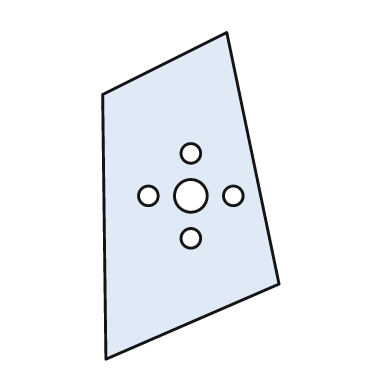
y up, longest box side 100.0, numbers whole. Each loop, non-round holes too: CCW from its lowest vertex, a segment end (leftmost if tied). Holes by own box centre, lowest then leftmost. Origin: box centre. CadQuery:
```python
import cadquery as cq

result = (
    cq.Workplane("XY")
    .moveTo(-26.0, -50.0)
    .lineTo(27.0, -27.0)
    .lineTo(11.0, 50.0)
    .lineTo(-27.0, 31.0)
    .close()
    .moveTo(0.0, -13.0)
    .circle(3.0)
    .moveTo(-13.0, 0.0)
    .circle(3.0)
    .moveTo(0.0, 0.0)
    .circle(5.0)
    .moveTo(13.0, 0.0)
    .circle(3.0)
    .moveTo(0.0, 13.0)
    .circle(3.0)
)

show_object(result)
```